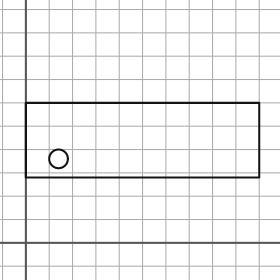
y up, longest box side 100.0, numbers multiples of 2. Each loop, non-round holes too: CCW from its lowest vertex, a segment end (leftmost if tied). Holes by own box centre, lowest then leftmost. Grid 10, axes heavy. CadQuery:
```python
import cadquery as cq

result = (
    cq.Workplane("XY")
    .moveTo(0.0, 28.0)
    .lineTo(100.0, 28.0)
    .lineTo(100.0, 60.0)
    .lineTo(0.0, 60.0)
    .close()
    .moveTo(14.0, 36.0)
    .circle(4.0)
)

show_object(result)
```